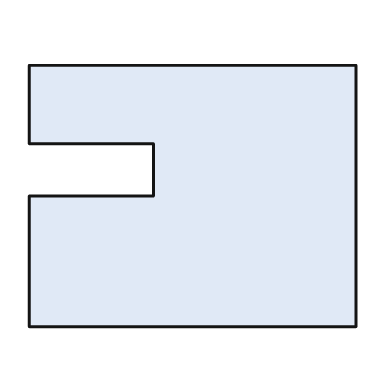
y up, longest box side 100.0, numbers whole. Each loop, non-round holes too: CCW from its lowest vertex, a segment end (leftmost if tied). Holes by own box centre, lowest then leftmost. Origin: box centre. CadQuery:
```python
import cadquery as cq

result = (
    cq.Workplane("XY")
    .moveTo(-50.0, -40.0)
    .lineTo(50.0, -40.0)
    .lineTo(50.0, 40.0)
    .lineTo(-50.0, 40.0)
    .lineTo(-50.0, 16.0)
    .lineTo(-12.0, 16.0)
    .lineTo(-12.0, 0.0)
    .lineTo(-50.0, 0.0)
    .close()
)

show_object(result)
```